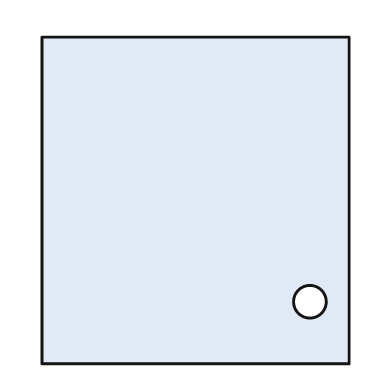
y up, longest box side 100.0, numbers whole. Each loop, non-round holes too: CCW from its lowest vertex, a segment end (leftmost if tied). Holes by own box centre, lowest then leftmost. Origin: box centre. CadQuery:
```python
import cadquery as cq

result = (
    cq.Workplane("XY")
    .moveTo(-47.0, -50.0)
    .lineTo(47.0, -50.0)
    .lineTo(47.0, 50.0)
    .lineTo(-47.0, 50.0)
    .close()
    .moveTo(35.0, -31.0)
    .circle(5.0)
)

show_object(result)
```